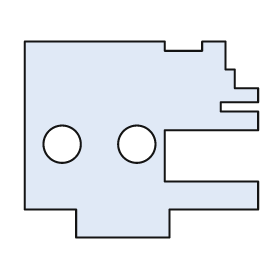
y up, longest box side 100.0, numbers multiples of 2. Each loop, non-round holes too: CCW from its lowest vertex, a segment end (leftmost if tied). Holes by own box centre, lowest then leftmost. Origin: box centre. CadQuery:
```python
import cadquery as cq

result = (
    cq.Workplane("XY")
    .moveTo(-28.0, -42.0)
    .lineTo(12.0, -42.0)
    .lineTo(12.0, -30.0)
    .lineTo(50.0, -30.0)
    .lineTo(50.0, -18.0)
    .lineTo(10.0, -18.0)
    .lineTo(10.0, 4.0)
    .lineTo(50.0, 4.0)
    .lineTo(50.0, 12.0)
    .lineTo(34.0, 12.0)
    .lineTo(34.0, 16.0)
    .lineTo(50.0, 16.0)
    .lineTo(50.0, 22.0)
    .lineTo(40.0, 22.0)
    .lineTo(40.0, 30.0)
    .lineTo(36.0, 30.0)
    .lineTo(36.0, 42.0)
    .lineTo(26.0, 42.0)
    .lineTo(26.0, 38.0)
    .lineTo(10.0, 38.0)
    .lineTo(10.0, 42.0)
    .lineTo(-50.0, 42.0)
    .lineTo(-50.0, -30.0)
    .lineTo(-28.0, -30.0)
    .close()
    .moveTo(-34.0, -2.0)
    .circle(8.0)
    .moveTo(-2.0, -2.0)
    .circle(8.0)
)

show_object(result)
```